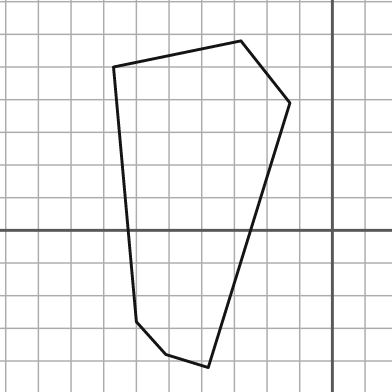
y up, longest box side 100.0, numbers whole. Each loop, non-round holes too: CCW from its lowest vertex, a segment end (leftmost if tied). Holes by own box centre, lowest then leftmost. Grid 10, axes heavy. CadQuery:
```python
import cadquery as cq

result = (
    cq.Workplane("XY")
    .moveTo(-38.0, -42.0)
    .lineTo(-13.0, 39.0)
    .lineTo(-28.0, 58.0)
    .lineTo(-67.0, 50.0)
    .lineTo(-60.0, -28.0)
    .lineTo(-51.0, -38.0)
    .close()
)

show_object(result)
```